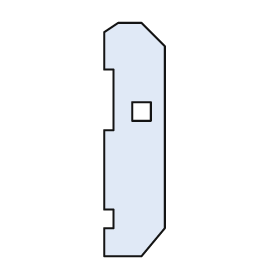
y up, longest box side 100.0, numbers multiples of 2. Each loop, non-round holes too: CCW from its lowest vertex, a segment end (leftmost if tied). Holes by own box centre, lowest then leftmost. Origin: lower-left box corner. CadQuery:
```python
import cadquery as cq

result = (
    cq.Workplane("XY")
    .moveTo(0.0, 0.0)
    .lineTo(16.0, 0.0)
    .lineTo(26.0, 12.0)
    .lineTo(26.0, 90.0)
    .lineTo(16.0, 100.0)
    .lineTo(6.0, 100.0)
    .lineTo(0.0, 96.0)
    .lineTo(0.0, 80.0)
    .lineTo(4.0, 80.0)
    .lineTo(4.0, 54.0)
    .lineTo(0.0, 54.0)
    .lineTo(0.0, 20.0)
    .lineTo(4.0, 20.0)
    .lineTo(4.0, 12.0)
    .lineTo(0.0, 12.0)
    .close()
    .moveTo(12.0, 58.0)
    .lineTo(20.0, 58.0)
    .lineTo(20.0, 66.0)
    .lineTo(12.0, 66.0)
    .close()
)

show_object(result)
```